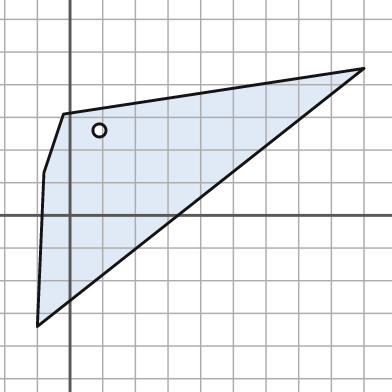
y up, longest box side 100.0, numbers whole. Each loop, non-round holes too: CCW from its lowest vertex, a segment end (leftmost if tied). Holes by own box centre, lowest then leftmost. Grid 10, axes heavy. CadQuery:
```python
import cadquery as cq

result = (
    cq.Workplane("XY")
    .moveTo(-10.0, -34.0)
    .lineTo(90.0, 45.0)
    .lineTo(-2.0, 31.0)
    .lineTo(-8.0, 13.0)
    .close()
    .moveTo(9.0, 26.0)
    .circle(2.0)
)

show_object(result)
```